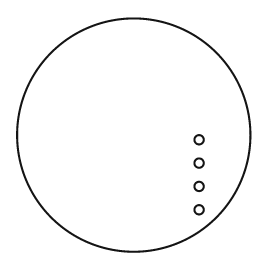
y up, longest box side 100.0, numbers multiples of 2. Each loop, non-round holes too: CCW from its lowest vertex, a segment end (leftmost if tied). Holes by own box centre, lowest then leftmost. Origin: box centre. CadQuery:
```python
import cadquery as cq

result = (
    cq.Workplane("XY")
    .moveTo(0.0, 0.0)
    .circle(50.0)
    .moveTo(28.0, -32.0)
    .circle(2.0)
    .moveTo(28.0, -22.0)
    .circle(2.0)
    .moveTo(28.0, -12.0)
    .circle(2.0)
    .moveTo(28.0, -2.0)
    .circle(2.0)
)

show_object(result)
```